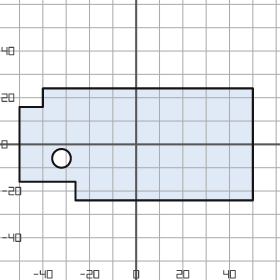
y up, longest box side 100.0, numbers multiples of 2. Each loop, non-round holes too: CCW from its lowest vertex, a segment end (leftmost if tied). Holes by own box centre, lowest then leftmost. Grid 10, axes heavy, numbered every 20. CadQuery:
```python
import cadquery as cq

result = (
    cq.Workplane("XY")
    .moveTo(-26.0, -24.0)
    .lineTo(50.0, -24.0)
    .lineTo(50.0, 24.0)
    .lineTo(-40.0, 24.0)
    .lineTo(-40.0, 16.0)
    .lineTo(-50.0, 16.0)
    .lineTo(-50.0, -16.0)
    .lineTo(-26.0, -16.0)
    .close()
    .moveTo(-32.0, -6.0)
    .circle(4.0)
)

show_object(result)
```